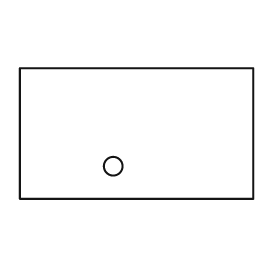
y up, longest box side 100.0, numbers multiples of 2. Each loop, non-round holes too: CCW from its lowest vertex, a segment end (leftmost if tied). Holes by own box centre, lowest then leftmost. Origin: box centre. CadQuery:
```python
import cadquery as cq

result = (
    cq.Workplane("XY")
    .moveTo(-50.0, -28.0)
    .lineTo(50.0, -28.0)
    .lineTo(50.0, 28.0)
    .lineTo(-50.0, 28.0)
    .close()
    .moveTo(-10.0, -14.0)
    .circle(4.0)
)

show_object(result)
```